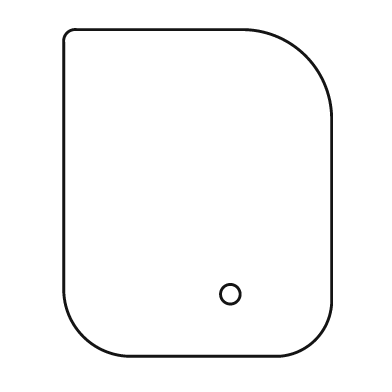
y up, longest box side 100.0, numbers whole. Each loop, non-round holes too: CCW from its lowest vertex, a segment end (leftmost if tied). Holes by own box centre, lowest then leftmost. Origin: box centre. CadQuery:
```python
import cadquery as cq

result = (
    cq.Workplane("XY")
    .moveTo(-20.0, -50.0)
    .lineTo(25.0, -50.0)
    .threePointArc((36.0, -45.0), (41.0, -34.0))
    .lineTo(41.0, 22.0)
    .threePointArc((33.0, 42.0), (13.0, 50.0))
    .lineTo(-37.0, 50.0)
    .threePointArc((-40.0, 49.0), (-41.0, 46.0))
    .lineTo(-41.0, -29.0)
    .threePointArc((-35.0, -44.0), (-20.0, -50.0))
    .close()
    .moveTo(10.0, -31.0)
    .circle(3.0)
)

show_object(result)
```